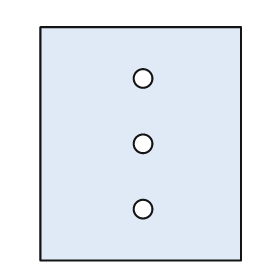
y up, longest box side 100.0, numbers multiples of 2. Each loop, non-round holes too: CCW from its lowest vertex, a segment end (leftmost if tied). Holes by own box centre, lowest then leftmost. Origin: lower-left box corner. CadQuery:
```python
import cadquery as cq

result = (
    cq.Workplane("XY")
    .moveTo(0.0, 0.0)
    .lineTo(86.0, 0.0)
    .lineTo(86.0, 100.0)
    .lineTo(0.0, 100.0)
    .close()
    .moveTo(44.0, 22.0)
    .circle(4.0)
    .moveTo(44.0, 50.0)
    .circle(4.0)
    .moveTo(44.0, 78.0)
    .circle(4.0)
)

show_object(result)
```